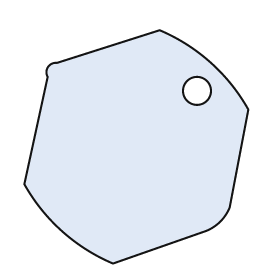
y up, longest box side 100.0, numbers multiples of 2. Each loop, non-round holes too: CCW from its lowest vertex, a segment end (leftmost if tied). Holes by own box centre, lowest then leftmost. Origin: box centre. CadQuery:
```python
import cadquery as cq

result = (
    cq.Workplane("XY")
    .moveTo(-10.0, -50.0)
    .lineTo(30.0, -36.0)
    .threePointArc((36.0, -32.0), (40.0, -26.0))
    .lineTo(48.0, 16.0)
    .threePointArc((32.0, 36.0), (10.0, 50.0))
    .lineTo(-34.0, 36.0)
    .threePointArc((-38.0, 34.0), (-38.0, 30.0))
    .lineTo(-48.0, -16.0)
    .threePointArc((-32.0, -36.0), (-10.0, -50.0))
    .close()
    .moveTo(26.0, 24.0)
    .circle(6.0)
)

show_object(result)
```